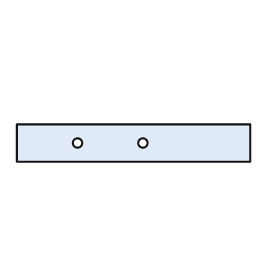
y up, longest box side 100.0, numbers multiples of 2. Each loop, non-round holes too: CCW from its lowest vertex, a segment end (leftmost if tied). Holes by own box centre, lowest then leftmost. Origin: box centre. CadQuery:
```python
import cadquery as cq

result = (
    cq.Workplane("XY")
    .moveTo(-50.0, -8.0)
    .lineTo(50.0, -8.0)
    .lineTo(50.0, 8.0)
    .lineTo(-50.0, 8.0)
    .close()
    .moveTo(-24.0, 0.0)
    .circle(2.0)
    .moveTo(4.0, 0.0)
    .circle(2.0)
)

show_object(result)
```